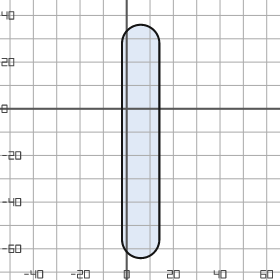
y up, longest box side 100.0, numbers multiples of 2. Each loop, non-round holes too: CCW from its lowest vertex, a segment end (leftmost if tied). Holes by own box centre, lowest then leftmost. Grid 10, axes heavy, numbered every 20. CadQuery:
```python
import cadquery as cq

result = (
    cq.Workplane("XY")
    .moveTo(-2.0, -56.0)
    .threePointArc((6.0, -64.0), (14.0, -56.0))
    .lineTo(14.0, 28.0)
    .threePointArc((6.0, 36.0), (-2.0, 28.0))
    .close()
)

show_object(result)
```